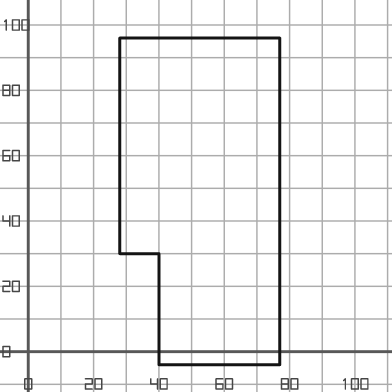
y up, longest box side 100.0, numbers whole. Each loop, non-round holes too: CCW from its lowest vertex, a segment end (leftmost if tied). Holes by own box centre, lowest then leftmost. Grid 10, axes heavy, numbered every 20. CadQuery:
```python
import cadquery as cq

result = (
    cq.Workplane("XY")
    .moveTo(40.0, -4.0)
    .lineTo(77.0, -4.0)
    .lineTo(77.0, 96.0)
    .lineTo(28.0, 96.0)
    .lineTo(28.0, 30.0)
    .lineTo(40.0, 30.0)
    .close()
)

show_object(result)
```